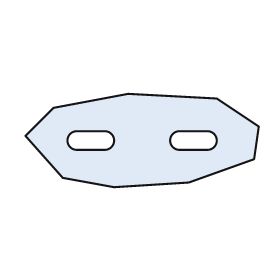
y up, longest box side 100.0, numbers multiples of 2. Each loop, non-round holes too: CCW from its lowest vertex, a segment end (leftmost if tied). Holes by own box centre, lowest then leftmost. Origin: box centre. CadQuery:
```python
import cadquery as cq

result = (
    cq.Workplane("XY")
    .moveTo(-12.0, -20.0)
    .lineTo(20.0, -18.0)
    .lineTo(48.0, -8.0)
    .lineTo(50.0, 6.0)
    .lineTo(32.0, 18.0)
    .lineTo(-6.0, 20.0)
    .lineTo(-38.0, 14.0)
    .lineTo(-50.0, 2.0)
    .lineTo(-34.0, -16.0)
    .close()
    .moveTo(-28.0, -4.0)
    .lineTo(-16.0, -4.0)
    .threePointArc((-12.0, 0.0), (-16.0, 4.0))
    .lineTo(-28.0, 4.0)
    .threePointArc((-32.0, 0.0), (-28.0, -4.0))
    .close()
    .moveTo(16.0, -4.0)
    .lineTo(28.0, -4.0)
    .threePointArc((32.0, 0.0), (28.0, 4.0))
    .lineTo(16.0, 4.0)
    .threePointArc((12.0, 0.0), (16.0, -4.0))
    .close()
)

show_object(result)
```